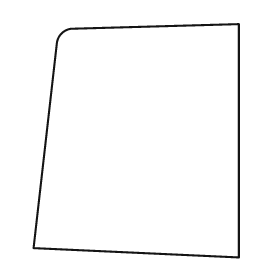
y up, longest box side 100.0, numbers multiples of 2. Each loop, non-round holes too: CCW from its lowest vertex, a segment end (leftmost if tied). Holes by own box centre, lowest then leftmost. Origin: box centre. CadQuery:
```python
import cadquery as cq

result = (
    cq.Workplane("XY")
    .moveTo(44.0, -50.0)
    .lineTo(44.0, 50.0)
    .lineTo(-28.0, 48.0)
    .threePointArc((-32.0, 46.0), (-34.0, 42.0))
    .lineTo(-44.0, -46.0)
    .close()
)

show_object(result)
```